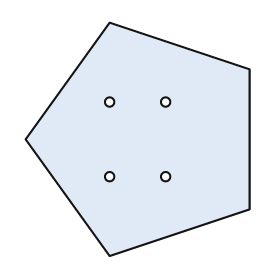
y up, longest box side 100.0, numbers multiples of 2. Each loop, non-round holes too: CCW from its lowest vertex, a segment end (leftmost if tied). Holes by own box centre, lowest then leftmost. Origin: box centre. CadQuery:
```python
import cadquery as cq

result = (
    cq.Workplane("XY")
    .moveTo(-12.0, -50.0)
    .lineTo(48.0, -30.0)
    .lineTo(48.0, 30.0)
    .lineTo(-12.0, 50.0)
    .lineTo(-48.0, 0.0)
    .close()
    .moveTo(-12.0, -16.0)
    .circle(2.0)
    .moveTo(12.0, -16.0)
    .circle(2.0)
    .moveTo(-12.0, 16.0)
    .circle(2.0)
    .moveTo(12.0, 16.0)
    .circle(2.0)
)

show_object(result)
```